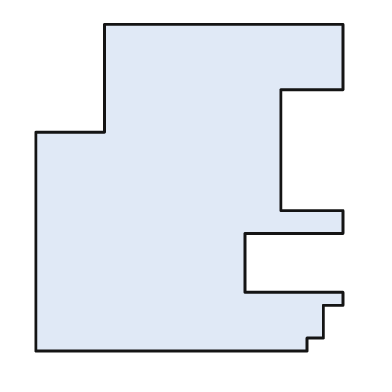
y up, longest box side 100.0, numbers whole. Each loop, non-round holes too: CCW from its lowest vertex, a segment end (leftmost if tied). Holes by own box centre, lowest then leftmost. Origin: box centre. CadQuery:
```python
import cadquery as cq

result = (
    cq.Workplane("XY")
    .moveTo(-47.0, -50.0)
    .lineTo(36.0, -50.0)
    .lineTo(36.0, -46.0)
    .lineTo(41.0, -46.0)
    .lineTo(41.0, -36.0)
    .lineTo(47.0, -36.0)
    .lineTo(47.0, -32.0)
    .lineTo(17.0, -32.0)
    .lineTo(17.0, -14.0)
    .lineTo(47.0, -14.0)
    .lineTo(47.0, -7.0)
    .lineTo(28.0, -7.0)
    .lineTo(28.0, 30.0)
    .lineTo(47.0, 30.0)
    .lineTo(47.0, 50.0)
    .lineTo(-26.0, 50.0)
    .lineTo(-26.0, 17.0)
    .lineTo(-47.0, 17.0)
    .close()
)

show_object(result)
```